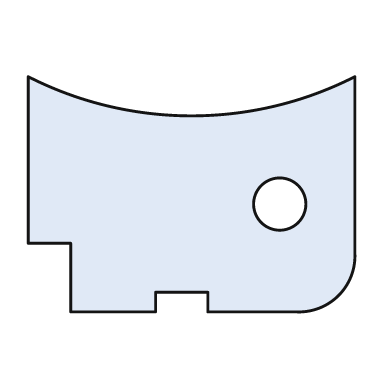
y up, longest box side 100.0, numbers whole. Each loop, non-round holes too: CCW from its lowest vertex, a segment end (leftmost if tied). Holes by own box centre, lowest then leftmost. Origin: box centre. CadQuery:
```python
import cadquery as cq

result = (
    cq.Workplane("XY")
    .moveTo(-37.0, -36.0)
    .lineTo(-11.0, -36.0)
    .lineTo(-11.0, -30.0)
    .lineTo(5.0, -30.0)
    .lineTo(5.0, -36.0)
    .lineTo(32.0, -36.0)
    .threePointArc((45.0, -31.0), (50.0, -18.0))
    .lineTo(50.0, 36.0)
    .threePointArc((0.0, 24.0), (-50.0, 36.0))
    .lineTo(-50.0, -15.0)
    .lineTo(-37.0, -15.0)
    .close()
    .moveTo(27.0, -3.0)
    .circle(8.0)
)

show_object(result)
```